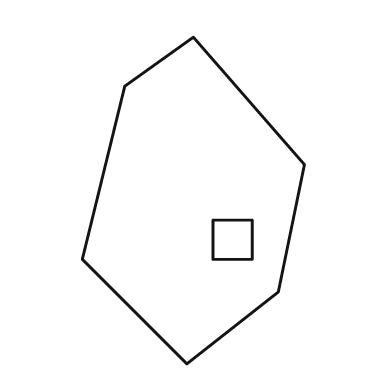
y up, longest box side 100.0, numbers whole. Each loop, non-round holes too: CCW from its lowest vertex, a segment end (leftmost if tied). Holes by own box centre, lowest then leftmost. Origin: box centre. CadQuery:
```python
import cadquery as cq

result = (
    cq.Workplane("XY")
    .moveTo(-2.0, -50.0)
    .lineTo(26.0, -28.0)
    .lineTo(34.0, 11.0)
    .lineTo(0.0, 50.0)
    .lineTo(-21.0, 35.0)
    .lineTo(-34.0, -18.0)
    .close()
    .moveTo(6.0, -18.0)
    .lineTo(18.0, -18.0)
    .lineTo(18.0, -6.0)
    .lineTo(6.0, -6.0)
    .close()
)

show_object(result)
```